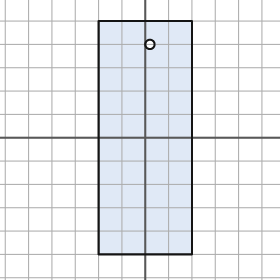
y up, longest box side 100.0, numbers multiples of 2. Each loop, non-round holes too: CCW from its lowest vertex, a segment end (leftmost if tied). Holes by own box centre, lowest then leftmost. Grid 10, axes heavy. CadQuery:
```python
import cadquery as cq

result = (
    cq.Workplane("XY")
    .moveTo(-20.0, -50.0)
    .lineTo(20.0, -50.0)
    .lineTo(20.0, 50.0)
    .lineTo(-20.0, 50.0)
    .close()
    .moveTo(2.0, 40.0)
    .circle(2.0)
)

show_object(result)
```